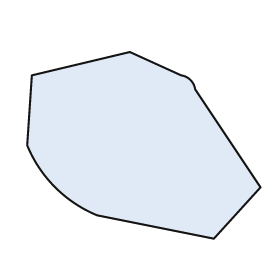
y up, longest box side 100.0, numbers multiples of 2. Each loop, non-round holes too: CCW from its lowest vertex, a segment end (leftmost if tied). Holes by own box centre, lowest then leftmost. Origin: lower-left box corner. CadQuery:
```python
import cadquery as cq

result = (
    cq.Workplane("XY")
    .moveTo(80.0, 0.0)
    .lineTo(100.0, 22.0)
    .lineTo(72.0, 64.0)
    .threePointArc((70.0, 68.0), (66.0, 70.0))
    .lineTo(44.0, 80.0)
    .lineTo(2.0, 70.0)
    .lineTo(0.0, 40.0)
    .threePointArc((12.0, 22.0), (30.0, 10.0))
    .close()
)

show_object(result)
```